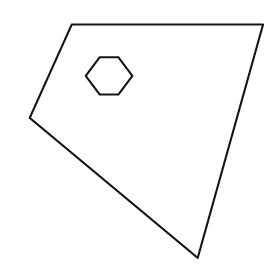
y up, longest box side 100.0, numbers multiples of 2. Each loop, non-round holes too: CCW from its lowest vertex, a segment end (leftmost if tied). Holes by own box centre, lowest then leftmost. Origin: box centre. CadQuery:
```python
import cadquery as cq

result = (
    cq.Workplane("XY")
    .moveTo(22.0, -50.0)
    .lineTo(50.0, 50.0)
    .lineTo(-32.0, 50.0)
    .lineTo(-50.0, 10.0)
    .close()
    .moveTo(-20.0, 20.0)
    .lineTo(-12.0, 20.0)
    .lineTo(-6.0, 28.0)
    .lineTo(-12.0, 36.0)
    .lineTo(-20.0, 36.0)
    .lineTo(-26.0, 28.0)
    .close()
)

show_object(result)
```